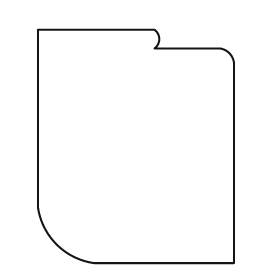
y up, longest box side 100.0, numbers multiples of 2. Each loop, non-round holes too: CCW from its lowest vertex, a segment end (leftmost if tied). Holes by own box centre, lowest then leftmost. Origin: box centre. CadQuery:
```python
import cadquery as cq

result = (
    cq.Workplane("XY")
    .moveTo(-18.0, -50.0)
    .lineTo(42.0, -50.0)
    .lineTo(42.0, 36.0)
    .threePointArc((40.0, 40.0), (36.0, 42.0))
    .lineTo(8.0, 42.0)
    .threePointArc((10.0, 46.0), (8.0, 50.0))
    .lineTo(-42.0, 50.0)
    .lineTo(-42.0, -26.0)
    .threePointArc((-34.0, -42.0), (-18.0, -50.0))
    .close()
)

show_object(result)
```